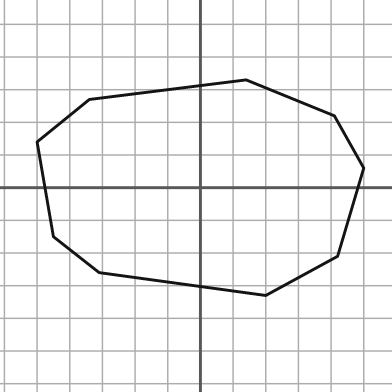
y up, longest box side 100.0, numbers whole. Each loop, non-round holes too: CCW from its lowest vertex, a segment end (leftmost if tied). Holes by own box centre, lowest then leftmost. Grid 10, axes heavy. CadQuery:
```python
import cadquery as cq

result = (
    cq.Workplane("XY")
    .moveTo(20.0, -33.0)
    .lineTo(42.0, -21.0)
    .lineTo(50.0, 6.0)
    .lineTo(41.0, 22.0)
    .lineTo(14.0, 33.0)
    .lineTo(-34.0, 27.0)
    .lineTo(-50.0, 14.0)
    .lineTo(-45.0, -15.0)
    .lineTo(-31.0, -26.0)
    .close()
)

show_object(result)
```